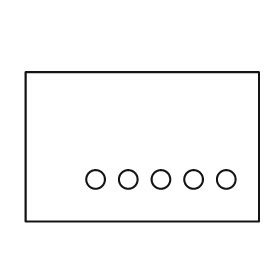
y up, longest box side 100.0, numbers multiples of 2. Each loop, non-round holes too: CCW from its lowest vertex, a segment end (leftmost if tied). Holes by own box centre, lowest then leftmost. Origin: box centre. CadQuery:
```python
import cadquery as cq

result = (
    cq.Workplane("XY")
    .moveTo(-50.0, -32.0)
    .lineTo(50.0, -32.0)
    .lineTo(50.0, 32.0)
    .lineTo(-50.0, 32.0)
    .close()
    .moveTo(-20.0, -14.0)
    .circle(4.0)
    .moveTo(-6.0, -14.0)
    .circle(4.0)
    .moveTo(8.0, -14.0)
    .circle(4.0)
    .moveTo(22.0, -14.0)
    .circle(4.0)
    .moveTo(36.0, -14.0)
    .circle(4.0)
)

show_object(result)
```